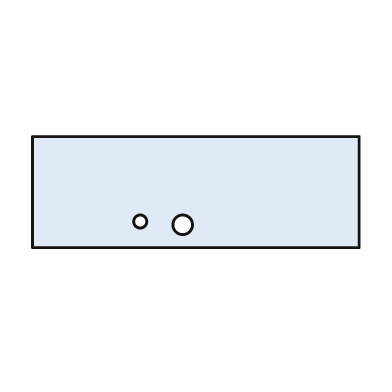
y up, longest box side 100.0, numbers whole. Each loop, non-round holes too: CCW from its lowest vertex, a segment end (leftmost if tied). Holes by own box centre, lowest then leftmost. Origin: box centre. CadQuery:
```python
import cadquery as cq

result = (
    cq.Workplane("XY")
    .moveTo(-50.0, -17.0)
    .lineTo(50.0, -17.0)
    .lineTo(50.0, 17.0)
    .lineTo(-50.0, 17.0)
    .close()
    .moveTo(-4.0, -10.0)
    .circle(3.0)
    .moveTo(-17.0, -9.0)
    .circle(2.0)
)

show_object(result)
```